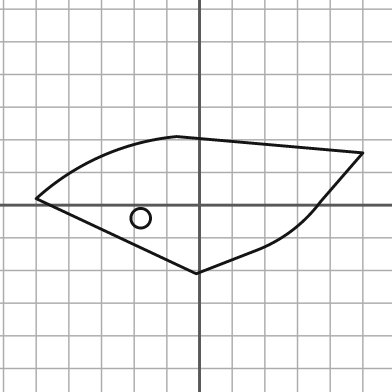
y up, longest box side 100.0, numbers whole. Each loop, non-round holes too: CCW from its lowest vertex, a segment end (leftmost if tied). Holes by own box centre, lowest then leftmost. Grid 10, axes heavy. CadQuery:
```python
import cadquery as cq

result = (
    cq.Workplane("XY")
    .moveTo(-1.0, -21.0)
    .lineTo(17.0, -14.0)
    .threePointArc((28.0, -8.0), (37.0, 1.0))
    .lineTo(50.0, 16.0)
    .lineTo(-7.0, 21.0)
    .threePointArc((-30.0, 15.0), (-50.0, 2.0))
    .close()
    .moveTo(-18.0, -4.0)
    .circle(3.0)
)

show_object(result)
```